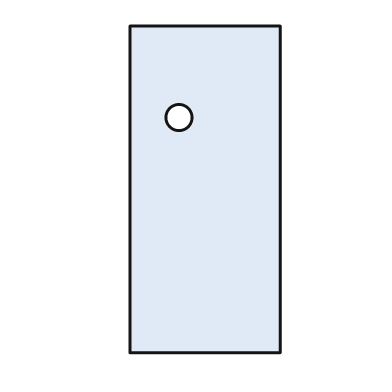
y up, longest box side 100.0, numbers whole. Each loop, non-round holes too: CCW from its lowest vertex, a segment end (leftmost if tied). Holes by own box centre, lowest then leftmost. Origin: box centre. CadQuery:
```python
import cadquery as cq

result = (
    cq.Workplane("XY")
    .moveTo(-23.0, -50.0)
    .lineTo(23.0, -50.0)
    .lineTo(23.0, 50.0)
    .lineTo(-23.0, 50.0)
    .close()
    .moveTo(-8.0, 22.0)
    .circle(4.0)
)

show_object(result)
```